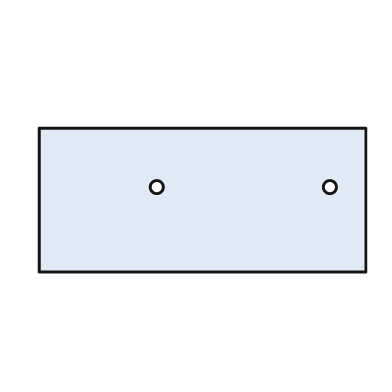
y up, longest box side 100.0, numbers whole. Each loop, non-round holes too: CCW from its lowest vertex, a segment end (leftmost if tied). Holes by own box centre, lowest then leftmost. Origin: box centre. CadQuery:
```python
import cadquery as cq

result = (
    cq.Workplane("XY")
    .moveTo(-50.0, -22.0)
    .lineTo(50.0, -22.0)
    .lineTo(50.0, 22.0)
    .lineTo(-50.0, 22.0)
    .close()
    .moveTo(-14.0, 4.0)
    .circle(2.0)
    .moveTo(39.0, 4.0)
    .circle(2.0)
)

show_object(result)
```